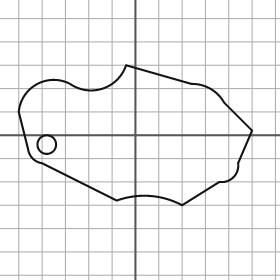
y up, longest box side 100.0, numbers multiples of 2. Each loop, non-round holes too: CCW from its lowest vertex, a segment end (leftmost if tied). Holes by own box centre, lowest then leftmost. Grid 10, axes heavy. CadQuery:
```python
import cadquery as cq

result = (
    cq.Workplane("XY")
    .moveTo(20.0, -30.0)
    .lineTo(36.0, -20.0)
    .threePointArc((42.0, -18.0), (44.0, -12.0))
    .lineTo(50.0, 2.0)
    .lineTo(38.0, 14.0)
    .threePointArc((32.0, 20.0), (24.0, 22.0))
    .lineTo(-4.0, 30.0)
    .threePointArc((-14.0, 20.0), (-28.0, 22.0))
    .threePointArc((-42.0, 22.0), (-50.0, 10.0))
    .lineTo(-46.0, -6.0)
    .threePointArc((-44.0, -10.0), (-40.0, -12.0))
    .lineTo(-8.0, -28.0)
    .threePointArc((6.0, -26.0), (20.0, -30.0))
    .close()
    .moveTo(-38.0, -4.0)
    .circle(4.0)
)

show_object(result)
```